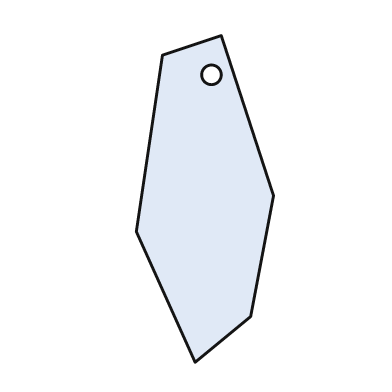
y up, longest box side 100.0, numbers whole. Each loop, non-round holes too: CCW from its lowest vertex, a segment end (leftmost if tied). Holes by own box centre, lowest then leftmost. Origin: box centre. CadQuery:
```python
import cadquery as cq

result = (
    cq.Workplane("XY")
    .moveTo(-3.0, -50.0)
    .lineTo(14.0, -36.0)
    .lineTo(21.0, 1.0)
    .lineTo(5.0, 50.0)
    .lineTo(-13.0, 44.0)
    .lineTo(-21.0, -10.0)
    .close()
    .moveTo(2.0, 38.0)
    .circle(3.0)
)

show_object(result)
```